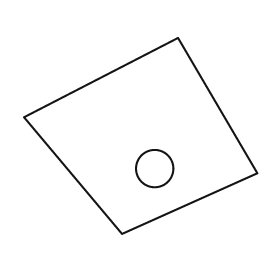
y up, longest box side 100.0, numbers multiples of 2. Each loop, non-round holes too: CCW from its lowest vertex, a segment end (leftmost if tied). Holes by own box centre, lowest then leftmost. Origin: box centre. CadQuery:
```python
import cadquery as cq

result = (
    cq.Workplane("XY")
    .moveTo(-8.0, -42.0)
    .lineTo(50.0, -16.0)
    .lineTo(16.0, 42.0)
    .lineTo(-50.0, 8.0)
    .close()
    .moveTo(6.0, -14.0)
    .circle(8.0)
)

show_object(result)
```